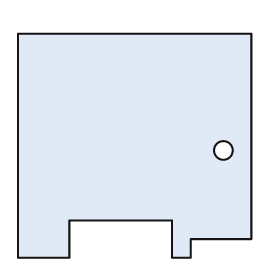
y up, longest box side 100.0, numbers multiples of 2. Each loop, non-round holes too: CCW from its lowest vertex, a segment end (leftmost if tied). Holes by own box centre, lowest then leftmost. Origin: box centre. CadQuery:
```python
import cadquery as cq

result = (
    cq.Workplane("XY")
    .moveTo(-50.0, -48.0)
    .lineTo(-28.0, -48.0)
    .lineTo(-28.0, -32.0)
    .lineTo(16.0, -32.0)
    .lineTo(16.0, -48.0)
    .lineTo(24.0, -48.0)
    .lineTo(24.0, -40.0)
    .lineTo(50.0, -40.0)
    .lineTo(50.0, 48.0)
    .lineTo(-50.0, 48.0)
    .close()
    .moveTo(38.0, -2.0)
    .circle(4.0)
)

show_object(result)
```